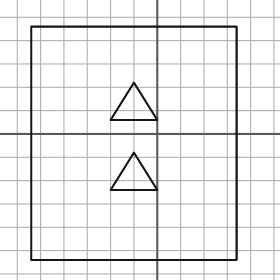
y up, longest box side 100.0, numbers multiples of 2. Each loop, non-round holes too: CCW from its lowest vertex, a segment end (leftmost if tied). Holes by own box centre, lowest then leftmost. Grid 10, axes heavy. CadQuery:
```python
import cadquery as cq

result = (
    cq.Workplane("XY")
    .moveTo(-54.0, -54.0)
    .lineTo(34.0, -54.0)
    .lineTo(34.0, 46.0)
    .lineTo(-54.0, 46.0)
    .close()
    .moveTo(-20.0, -24.0)
    .lineTo(0.0, -24.0)
    .lineTo(-10.0, -8.0)
    .close()
    .moveTo(-20.0, 6.0)
    .lineTo(0.0, 6.0)
    .lineTo(-10.0, 22.0)
    .close()
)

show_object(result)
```